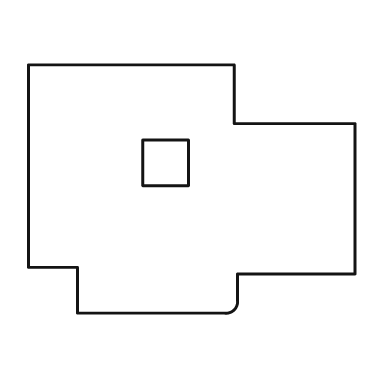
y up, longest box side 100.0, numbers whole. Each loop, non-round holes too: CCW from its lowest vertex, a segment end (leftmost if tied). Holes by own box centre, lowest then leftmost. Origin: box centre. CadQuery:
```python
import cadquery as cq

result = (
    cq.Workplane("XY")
    .moveTo(-35.0, -38.0)
    .lineTo(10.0, -38.0)
    .threePointArc((13.0, -37.0), (14.0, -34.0))
    .lineTo(14.0, -26.0)
    .lineTo(50.0, -26.0)
    .lineTo(50.0, 20.0)
    .lineTo(13.0, 20.0)
    .lineTo(13.0, 38.0)
    .lineTo(-50.0, 38.0)
    .lineTo(-50.0, -24.0)
    .lineTo(-35.0, -24.0)
    .close()
    .moveTo(-15.0, 1.0)
    .lineTo(-1.0, 1.0)
    .lineTo(-1.0, 15.0)
    .lineTo(-15.0, 15.0)
    .close()
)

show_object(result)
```